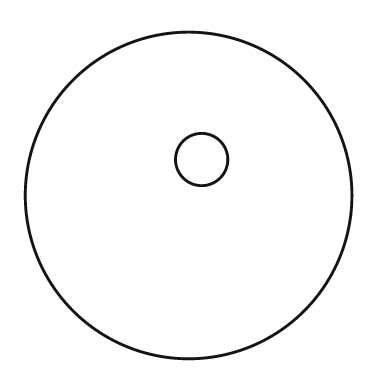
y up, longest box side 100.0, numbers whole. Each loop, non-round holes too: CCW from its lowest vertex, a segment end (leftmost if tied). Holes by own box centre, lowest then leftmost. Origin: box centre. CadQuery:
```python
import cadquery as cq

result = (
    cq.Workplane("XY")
    .moveTo(0.0, 0.0)
    .circle(50.0)
    .moveTo(4.0, 11.0)
    .circle(8.0)
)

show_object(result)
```